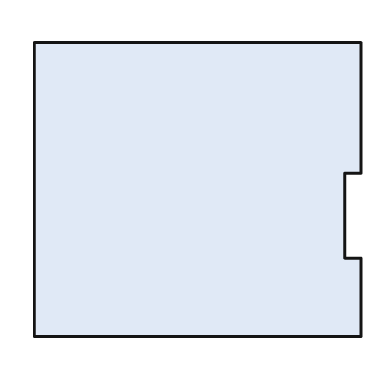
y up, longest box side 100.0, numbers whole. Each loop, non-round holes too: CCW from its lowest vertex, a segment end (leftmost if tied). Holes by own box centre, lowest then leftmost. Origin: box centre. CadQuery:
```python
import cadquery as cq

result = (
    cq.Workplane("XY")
    .moveTo(-50.0, -45.0)
    .lineTo(50.0, -45.0)
    .lineTo(50.0, -21.0)
    .lineTo(45.0, -21.0)
    .lineTo(45.0, 5.0)
    .lineTo(50.0, 5.0)
    .lineTo(50.0, 45.0)
    .lineTo(-50.0, 45.0)
    .close()
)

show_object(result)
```